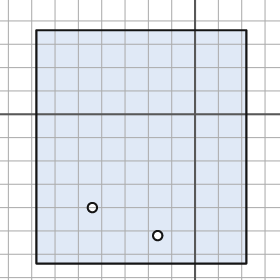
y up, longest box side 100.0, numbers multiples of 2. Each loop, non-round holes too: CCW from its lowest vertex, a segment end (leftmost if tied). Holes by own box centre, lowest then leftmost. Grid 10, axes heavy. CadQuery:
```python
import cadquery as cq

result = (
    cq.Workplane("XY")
    .moveTo(-68.0, -64.0)
    .lineTo(22.0, -64.0)
    .lineTo(22.0, 36.0)
    .lineTo(-68.0, 36.0)
    .close()
    .moveTo(-16.0, -52.0)
    .circle(2.0)
    .moveTo(-44.0, -40.0)
    .circle(2.0)
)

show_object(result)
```